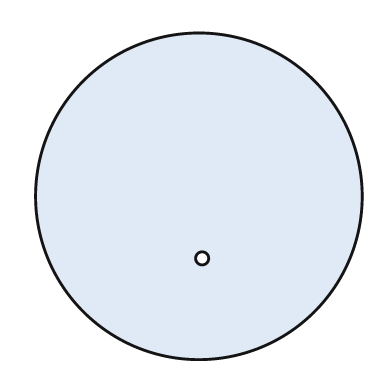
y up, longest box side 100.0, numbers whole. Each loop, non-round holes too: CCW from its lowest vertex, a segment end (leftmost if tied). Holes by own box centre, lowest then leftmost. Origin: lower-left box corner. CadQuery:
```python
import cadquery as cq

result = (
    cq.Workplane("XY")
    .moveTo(50.0, 50.0)
    .circle(50.0)
    .moveTo(51.0, 31.0)
    .circle(2.0)
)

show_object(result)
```